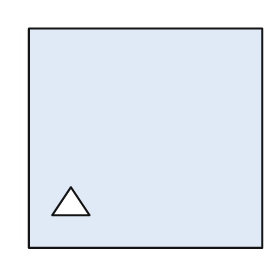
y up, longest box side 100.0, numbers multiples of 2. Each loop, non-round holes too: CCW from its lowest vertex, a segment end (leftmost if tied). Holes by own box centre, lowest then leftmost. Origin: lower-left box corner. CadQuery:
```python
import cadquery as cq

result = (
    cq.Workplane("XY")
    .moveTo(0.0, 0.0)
    .lineTo(100.0, 0.0)
    .lineTo(100.0, 94.0)
    .lineTo(0.0, 94.0)
    .close()
    .moveTo(10.0, 14.0)
    .lineTo(26.0, 14.0)
    .lineTo(18.0, 26.0)
    .close()
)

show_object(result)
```